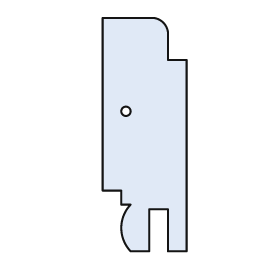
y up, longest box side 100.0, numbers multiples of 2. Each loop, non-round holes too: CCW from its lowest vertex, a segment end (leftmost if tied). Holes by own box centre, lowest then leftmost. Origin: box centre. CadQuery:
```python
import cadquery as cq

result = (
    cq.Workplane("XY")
    .moveTo(-6.0, -50.0)
    .lineTo(2.0, -50.0)
    .lineTo(2.0, -32.0)
    .lineTo(10.0, -32.0)
    .lineTo(10.0, -50.0)
    .lineTo(18.0, -50.0)
    .lineTo(18.0, 32.0)
    .lineTo(10.0, 32.0)
    .lineTo(10.0, 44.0)
    .threePointArc((8.0, 48.0), (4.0, 50.0))
    .lineTo(-18.0, 50.0)
    .lineTo(-18.0, -24.0)
    .lineTo(-10.0, -24.0)
    .lineTo(-10.0, -30.0)
    .lineTo(-6.0, -30.0)
    .threePointArc((-10.0, -40.0), (-6.0, -50.0))
    .close()
    .moveTo(-8.0, 10.0)
    .circle(2.0)
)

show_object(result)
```